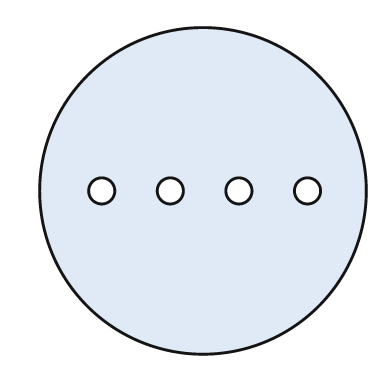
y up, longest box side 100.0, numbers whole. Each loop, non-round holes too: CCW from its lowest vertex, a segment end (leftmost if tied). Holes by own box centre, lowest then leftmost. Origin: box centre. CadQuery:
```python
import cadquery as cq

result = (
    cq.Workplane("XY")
    .moveTo(0.0, 0.0)
    .circle(50.0)
    .moveTo(-31.0, 0.0)
    .circle(4.0)
    .moveTo(-10.0, 0.0)
    .circle(4.0)
    .moveTo(11.0, 0.0)
    .circle(4.0)
    .moveTo(32.0, 0.0)
    .circle(4.0)
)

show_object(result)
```